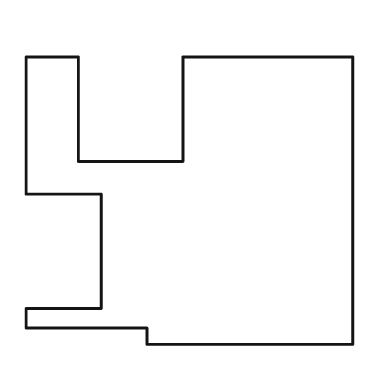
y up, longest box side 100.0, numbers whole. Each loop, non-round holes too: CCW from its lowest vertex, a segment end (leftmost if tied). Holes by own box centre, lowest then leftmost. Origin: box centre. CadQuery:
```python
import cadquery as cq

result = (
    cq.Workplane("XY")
    .moveTo(-13.0, -44.0)
    .lineTo(50.0, -44.0)
    .lineTo(50.0, 44.0)
    .lineTo(-2.0, 44.0)
    .lineTo(-2.0, 12.0)
    .lineTo(-34.0, 12.0)
    .lineTo(-34.0, 44.0)
    .lineTo(-50.0, 44.0)
    .lineTo(-50.0, 2.0)
    .lineTo(-27.0, 2.0)
    .lineTo(-27.0, -33.0)
    .lineTo(-50.0, -33.0)
    .lineTo(-50.0, -39.0)
    .lineTo(-13.0, -39.0)
    .close()
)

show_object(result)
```